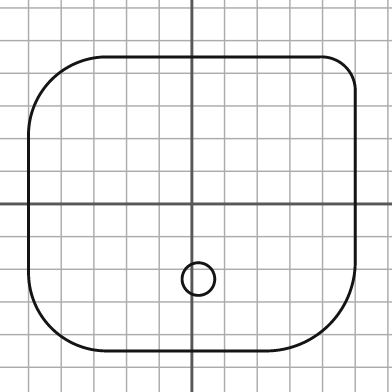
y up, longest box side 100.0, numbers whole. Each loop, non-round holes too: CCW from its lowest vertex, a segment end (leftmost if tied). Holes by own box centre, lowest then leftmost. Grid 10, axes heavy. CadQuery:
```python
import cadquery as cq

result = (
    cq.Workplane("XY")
    .moveTo(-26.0, -45.0)
    .lineTo(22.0, -45.0)
    .threePointArc((42.0, -37.0), (50.0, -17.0))
    .lineTo(50.0, 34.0)
    .threePointArc((47.0, 42.0), (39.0, 45.0))
    .lineTo(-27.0, 45.0)
    .threePointArc((-43.0, 38.0), (-50.0, 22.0))
    .lineTo(-50.0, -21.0)
    .threePointArc((-43.0, -38.0), (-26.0, -45.0))
    .close()
    .moveTo(2.0, -23.0)
    .circle(5.0)
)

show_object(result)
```